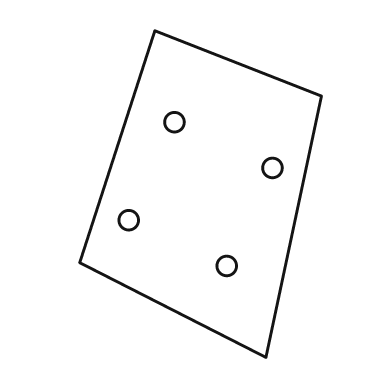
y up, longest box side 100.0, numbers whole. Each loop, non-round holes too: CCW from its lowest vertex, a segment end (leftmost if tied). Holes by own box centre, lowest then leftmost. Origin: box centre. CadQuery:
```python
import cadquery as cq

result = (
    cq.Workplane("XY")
    .moveTo(20.0, -50.0)
    .lineTo(37.0, 30.0)
    .lineTo(-14.0, 50.0)
    .lineTo(-37.0, -21.0)
    .close()
    .moveTo(8.0, -22.0)
    .circle(3.0)
    .moveTo(-22.0, -8.0)
    .circle(3.0)
    .moveTo(22.0, 8.0)
    .circle(3.0)
    .moveTo(-8.0, 22.0)
    .circle(3.0)
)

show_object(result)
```